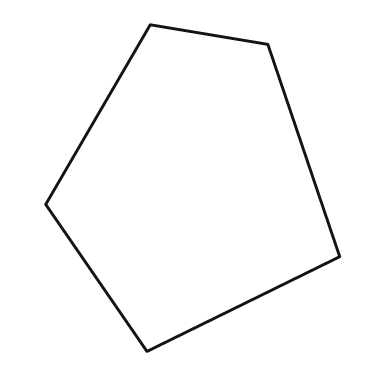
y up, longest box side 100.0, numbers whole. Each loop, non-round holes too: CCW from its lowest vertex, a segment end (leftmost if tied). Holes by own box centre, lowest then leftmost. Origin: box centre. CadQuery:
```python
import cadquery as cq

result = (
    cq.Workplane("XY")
    .moveTo(-14.0, -50.0)
    .lineTo(45.0, -21.0)
    .lineTo(23.0, 44.0)
    .lineTo(-13.0, 50.0)
    .lineTo(-45.0, -5.0)
    .close()
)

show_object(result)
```